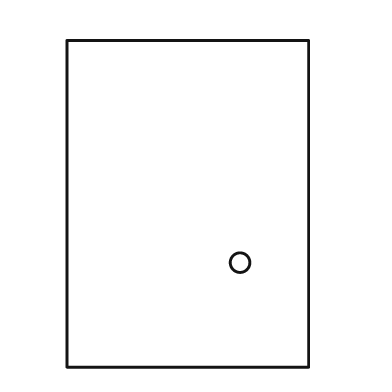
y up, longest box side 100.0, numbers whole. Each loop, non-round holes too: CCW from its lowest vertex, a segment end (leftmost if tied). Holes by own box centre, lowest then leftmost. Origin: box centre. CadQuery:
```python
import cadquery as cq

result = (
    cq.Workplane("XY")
    .moveTo(-37.0, -50.0)
    .lineTo(37.0, -50.0)
    .lineTo(37.0, 50.0)
    .lineTo(-37.0, 50.0)
    .close()
    .moveTo(16.0, -18.0)
    .circle(3.0)
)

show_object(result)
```